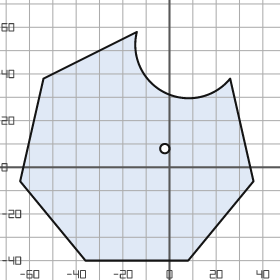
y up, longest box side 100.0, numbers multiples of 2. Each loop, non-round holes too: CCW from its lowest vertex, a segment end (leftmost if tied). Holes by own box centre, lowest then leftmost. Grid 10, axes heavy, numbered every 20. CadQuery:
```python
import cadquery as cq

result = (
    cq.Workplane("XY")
    .moveTo(-36.0, -40.0)
    .lineTo(8.0, -40.0)
    .lineTo(36.0, -6.0)
    .lineTo(26.0, 38.0)
    .threePointArc((-2.0, 32.0), (-14.0, 58.0))
    .lineTo(-54.0, 38.0)
    .lineTo(-64.0, -6.0)
    .close()
    .moveTo(-2.0, 8.0)
    .circle(2.0)
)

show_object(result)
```